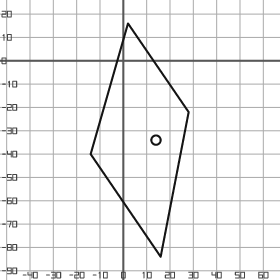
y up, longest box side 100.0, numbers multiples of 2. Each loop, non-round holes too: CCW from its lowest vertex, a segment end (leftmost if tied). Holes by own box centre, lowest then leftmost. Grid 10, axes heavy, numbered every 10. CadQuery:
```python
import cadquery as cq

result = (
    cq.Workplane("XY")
    .moveTo(16.0, -84.0)
    .lineTo(28.0, -22.0)
    .lineTo(2.0, 16.0)
    .lineTo(-14.0, -40.0)
    .close()
    .moveTo(14.0, -34.0)
    .circle(2.0)
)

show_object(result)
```